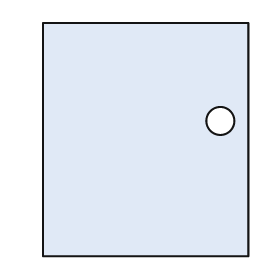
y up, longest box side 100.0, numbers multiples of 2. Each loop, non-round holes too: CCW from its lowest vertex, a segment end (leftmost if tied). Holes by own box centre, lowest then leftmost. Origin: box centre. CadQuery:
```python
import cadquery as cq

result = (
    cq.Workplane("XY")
    .moveTo(-44.0, -50.0)
    .lineTo(44.0, -50.0)
    .lineTo(44.0, 50.0)
    .lineTo(-44.0, 50.0)
    .close()
    .moveTo(32.0, 8.0)
    .circle(6.0)
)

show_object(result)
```